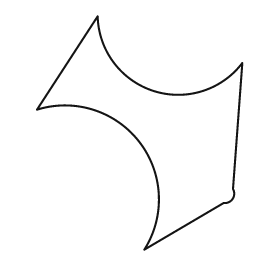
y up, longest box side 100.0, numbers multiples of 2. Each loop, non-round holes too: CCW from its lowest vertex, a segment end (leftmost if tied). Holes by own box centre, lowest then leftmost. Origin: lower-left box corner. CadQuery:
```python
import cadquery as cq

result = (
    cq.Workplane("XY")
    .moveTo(46.0, 0.0)
    .lineTo(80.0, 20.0)
    .threePointArc((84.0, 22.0), (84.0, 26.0))
    .lineTo(88.0, 80.0)
    .threePointArc((50.0, 68.0), (26.0, 100.0))
    .lineTo(0.0, 60.0)
    .threePointArc((44.0, 46.0), (46.0, 0.0))
    .close()
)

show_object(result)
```